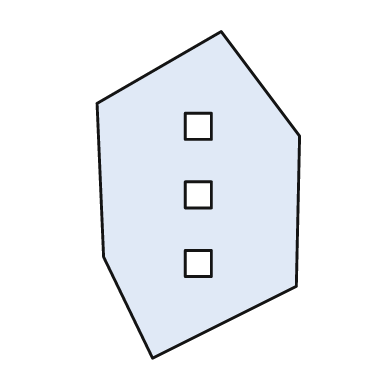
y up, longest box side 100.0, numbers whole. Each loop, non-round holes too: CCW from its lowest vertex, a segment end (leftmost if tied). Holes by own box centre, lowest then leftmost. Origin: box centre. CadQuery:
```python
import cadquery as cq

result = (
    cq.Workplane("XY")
    .moveTo(-14.0, -50.0)
    .lineTo(30.0, -28.0)
    .lineTo(31.0, 18.0)
    .lineTo(7.0, 50.0)
    .lineTo(-31.0, 28.0)
    .lineTo(-29.0, -19.0)
    .close()
    .moveTo(-4.0, -25.0)
    .lineTo(4.0, -25.0)
    .lineTo(4.0, -17.0)
    .lineTo(-4.0, -17.0)
    .close()
    .moveTo(-4.0, -4.0)
    .lineTo(4.0, -4.0)
    .lineTo(4.0, 4.0)
    .lineTo(-4.0, 4.0)
    .close()
    .moveTo(-4.0, 17.0)
    .lineTo(4.0, 17.0)
    .lineTo(4.0, 25.0)
    .lineTo(-4.0, 25.0)
    .close()
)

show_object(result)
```